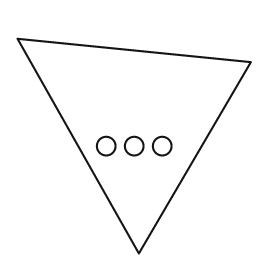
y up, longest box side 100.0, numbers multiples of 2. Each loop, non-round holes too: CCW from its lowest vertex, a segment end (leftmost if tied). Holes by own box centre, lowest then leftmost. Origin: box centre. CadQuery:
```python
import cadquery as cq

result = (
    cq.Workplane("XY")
    .moveTo(2.0, -46.0)
    .lineTo(50.0, 36.0)
    .lineTo(-50.0, 46.0)
    .close()
    .moveTo(-12.0, 0.0)
    .circle(4.0)
    .moveTo(0.0, 0.0)
    .circle(4.0)
    .moveTo(12.0, 0.0)
    .circle(4.0)
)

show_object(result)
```